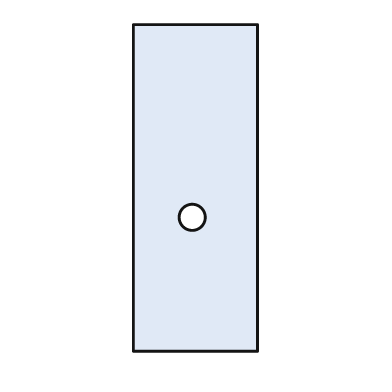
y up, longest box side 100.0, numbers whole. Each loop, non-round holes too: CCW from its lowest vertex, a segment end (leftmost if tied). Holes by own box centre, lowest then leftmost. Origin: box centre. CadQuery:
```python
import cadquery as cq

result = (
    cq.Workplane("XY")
    .moveTo(-19.0, -50.0)
    .lineTo(19.0, -50.0)
    .lineTo(19.0, 50.0)
    .lineTo(-19.0, 50.0)
    .close()
    .moveTo(-1.0, -9.0)
    .circle(4.0)
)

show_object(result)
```